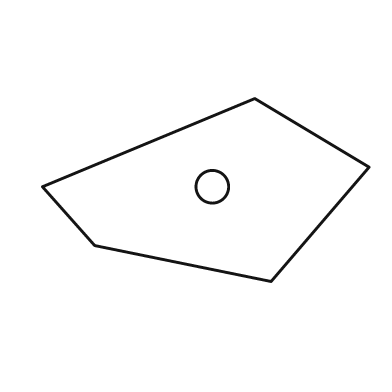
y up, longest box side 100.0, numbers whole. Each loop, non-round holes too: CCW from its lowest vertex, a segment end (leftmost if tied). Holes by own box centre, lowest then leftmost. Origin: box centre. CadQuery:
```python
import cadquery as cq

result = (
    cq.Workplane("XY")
    .moveTo(20.0, -28.0)
    .lineTo(50.0, 7.0)
    .lineTo(15.0, 28.0)
    .lineTo(-50.0, 1.0)
    .lineTo(-34.0, -17.0)
    .close()
    .moveTo(2.0, 1.0)
    .circle(5.0)
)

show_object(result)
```